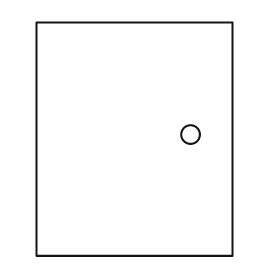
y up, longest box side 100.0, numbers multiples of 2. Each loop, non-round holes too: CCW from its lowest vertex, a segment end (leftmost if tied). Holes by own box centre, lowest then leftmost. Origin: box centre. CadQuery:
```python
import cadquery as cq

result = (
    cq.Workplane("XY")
    .moveTo(-42.0, -50.0)
    .lineTo(42.0, -50.0)
    .lineTo(42.0, 50.0)
    .lineTo(-42.0, 50.0)
    .close()
    .moveTo(24.0, 2.0)
    .circle(4.0)
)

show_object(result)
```